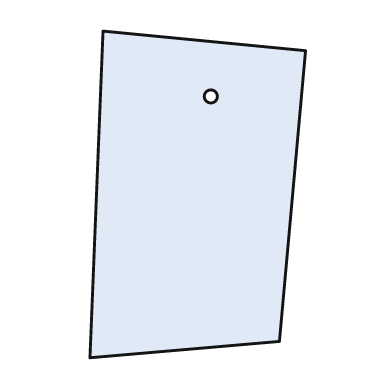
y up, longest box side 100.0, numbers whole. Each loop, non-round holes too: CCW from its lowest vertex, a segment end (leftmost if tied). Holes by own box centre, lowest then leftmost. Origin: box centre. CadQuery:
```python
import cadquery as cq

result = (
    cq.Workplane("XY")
    .moveTo(-33.0, -50.0)
    .lineTo(25.0, -45.0)
    .lineTo(33.0, 44.0)
    .lineTo(-29.0, 50.0)
    .close()
    .moveTo(4.0, 30.0)
    .circle(2.0)
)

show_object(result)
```